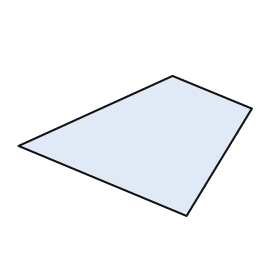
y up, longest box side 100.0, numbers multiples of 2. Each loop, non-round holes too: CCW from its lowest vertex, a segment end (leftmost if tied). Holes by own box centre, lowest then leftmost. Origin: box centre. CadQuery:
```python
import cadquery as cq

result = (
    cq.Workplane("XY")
    .moveTo(22.0, -30.0)
    .lineTo(50.0, 16.0)
    .lineTo(16.0, 30.0)
    .lineTo(-50.0, 0.0)
    .close()
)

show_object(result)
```